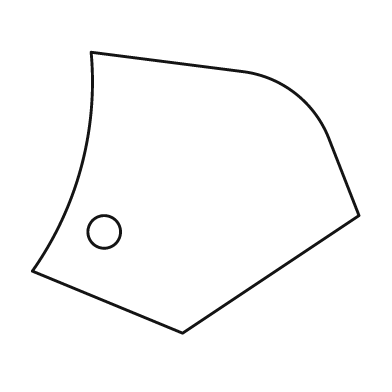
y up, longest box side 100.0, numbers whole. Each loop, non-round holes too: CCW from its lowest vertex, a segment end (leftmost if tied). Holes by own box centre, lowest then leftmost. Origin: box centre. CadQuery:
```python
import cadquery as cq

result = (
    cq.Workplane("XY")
    .moveTo(-4.0, -43.0)
    .lineTo(50.0, -7.0)
    .lineTo(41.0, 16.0)
    .threePointArc((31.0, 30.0), (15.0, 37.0))
    .lineTo(-32.0, 43.0)
    .threePointArc((-35.0, 8.0), (-50.0, -24.0))
    .close()
    .moveTo(-28.0, -12.0)
    .circle(5.0)
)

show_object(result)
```